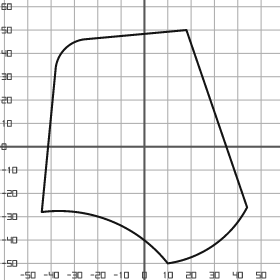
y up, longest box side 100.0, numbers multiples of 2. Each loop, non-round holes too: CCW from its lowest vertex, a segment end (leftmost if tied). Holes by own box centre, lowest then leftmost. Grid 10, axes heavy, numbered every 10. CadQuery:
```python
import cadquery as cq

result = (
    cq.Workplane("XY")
    .moveTo(10.0, -50.0)
    .threePointArc((30.0, -42.0), (44.0, -26.0))
    .lineTo(18.0, 50.0)
    .lineTo(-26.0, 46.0)
    .threePointArc((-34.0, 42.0), (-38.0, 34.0))
    .lineTo(-44.0, -28.0)
    .threePointArc((-14.0, -32.0), (10.0, -50.0))
    .close()
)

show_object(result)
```